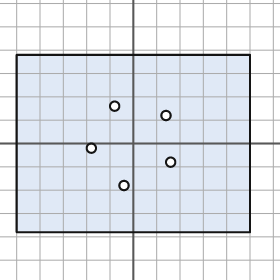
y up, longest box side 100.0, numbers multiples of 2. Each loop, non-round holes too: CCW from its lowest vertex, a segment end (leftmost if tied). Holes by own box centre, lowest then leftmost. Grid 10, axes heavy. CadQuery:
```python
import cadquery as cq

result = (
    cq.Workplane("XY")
    .moveTo(-50.0, -38.0)
    .lineTo(50.0, -38.0)
    .lineTo(50.0, 38.0)
    .lineTo(-50.0, 38.0)
    .close()
    .moveTo(-4.0, -18.0)
    .circle(2.0)
    .moveTo(16.0, -8.0)
    .circle(2.0)
    .moveTo(-18.0, -2.0)
    .circle(2.0)
    .moveTo(14.0, 12.0)
    .circle(2.0)
    .moveTo(-8.0, 16.0)
    .circle(2.0)
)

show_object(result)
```